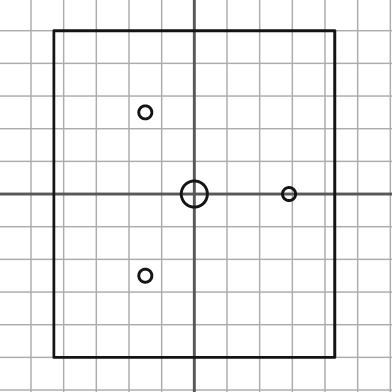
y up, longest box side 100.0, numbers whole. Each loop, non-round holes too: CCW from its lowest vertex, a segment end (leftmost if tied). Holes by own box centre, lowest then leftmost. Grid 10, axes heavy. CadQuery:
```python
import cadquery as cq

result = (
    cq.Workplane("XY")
    .moveTo(-43.0, -50.0)
    .lineTo(43.0, -50.0)
    .lineTo(43.0, 50.0)
    .lineTo(-43.0, 50.0)
    .close()
    .moveTo(-15.0, -25.0)
    .circle(2.0)
    .moveTo(0.0, 0.0)
    .circle(4.0)
    .moveTo(29.0, 0.0)
    .circle(2.0)
    .moveTo(-15.0, 25.0)
    .circle(2.0)
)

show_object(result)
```